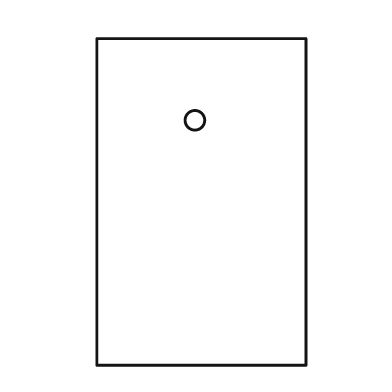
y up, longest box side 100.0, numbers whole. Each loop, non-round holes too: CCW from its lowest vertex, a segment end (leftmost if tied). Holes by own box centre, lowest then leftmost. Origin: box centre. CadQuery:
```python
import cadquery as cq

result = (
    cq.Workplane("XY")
    .moveTo(-32.0, -50.0)
    .lineTo(32.0, -50.0)
    .lineTo(32.0, 50.0)
    .lineTo(-32.0, 50.0)
    .close()
    .moveTo(-2.0, 25.0)
    .circle(3.0)
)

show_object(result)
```